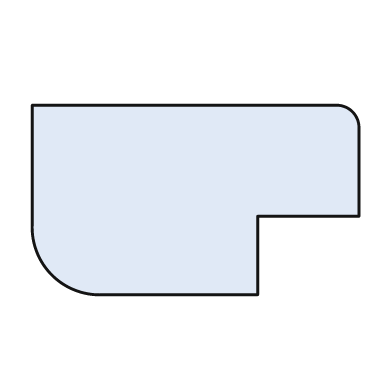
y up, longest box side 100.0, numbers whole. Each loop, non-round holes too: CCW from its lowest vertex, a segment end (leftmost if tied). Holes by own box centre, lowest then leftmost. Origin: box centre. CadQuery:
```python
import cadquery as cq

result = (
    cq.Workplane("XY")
    .moveTo(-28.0, -29.0)
    .lineTo(19.0, -29.0)
    .lineTo(19.0, -5.0)
    .lineTo(50.0, -5.0)
    .lineTo(50.0, 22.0)
    .threePointArc((48.0, 27.0), (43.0, 29.0))
    .lineTo(-50.0, 29.0)
    .lineTo(-50.0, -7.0)
    .threePointArc((-44.0, -23.0), (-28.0, -29.0))
    .close()
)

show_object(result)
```